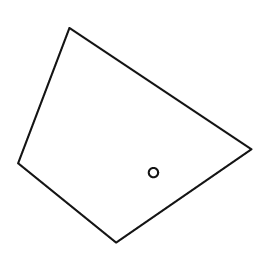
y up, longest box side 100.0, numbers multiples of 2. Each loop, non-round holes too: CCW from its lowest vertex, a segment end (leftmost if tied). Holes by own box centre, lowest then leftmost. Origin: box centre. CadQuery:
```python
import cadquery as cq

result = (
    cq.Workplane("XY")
    .moveTo(-8.0, -46.0)
    .lineTo(50.0, -6.0)
    .lineTo(-28.0, 46.0)
    .lineTo(-50.0, -12.0)
    .close()
    .moveTo(8.0, -16.0)
    .circle(2.0)
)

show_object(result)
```